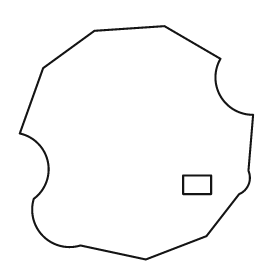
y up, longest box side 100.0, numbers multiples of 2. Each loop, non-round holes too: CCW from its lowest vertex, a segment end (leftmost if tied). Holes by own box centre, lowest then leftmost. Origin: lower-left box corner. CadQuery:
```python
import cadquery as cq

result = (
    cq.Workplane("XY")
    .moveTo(54.0, 0.0)
    .lineTo(80.0, 10.0)
    .lineTo(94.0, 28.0)
    .threePointArc((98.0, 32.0), (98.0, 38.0))
    .lineTo(100.0, 62.0)
    .threePointArc((86.0, 70.0), (86.0, 86.0))
    .lineTo(62.0, 100.0)
    .lineTo(32.0, 98.0)
    .lineTo(10.0, 82.0)
    .lineTo(0.0, 54.0)
    .threePointArc((12.0, 42.0), (6.0, 26.0))
    .threePointArc((10.0, 10.0), (26.0, 6.0))
    .close()
    .moveTo(70.0, 28.0)
    .lineTo(82.0, 28.0)
    .lineTo(82.0, 36.0)
    .lineTo(70.0, 36.0)
    .close()
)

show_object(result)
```